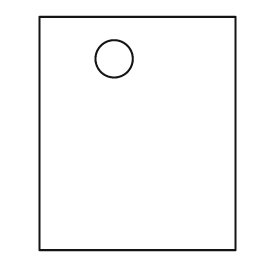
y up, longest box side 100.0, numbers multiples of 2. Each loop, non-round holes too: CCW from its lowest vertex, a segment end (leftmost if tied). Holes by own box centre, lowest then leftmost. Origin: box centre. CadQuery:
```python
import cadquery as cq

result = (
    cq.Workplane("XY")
    .moveTo(-42.0, -50.0)
    .lineTo(42.0, -50.0)
    .lineTo(42.0, 50.0)
    .lineTo(-42.0, 50.0)
    .close()
    .moveTo(-10.0, 32.0)
    .circle(8.0)
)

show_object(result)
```